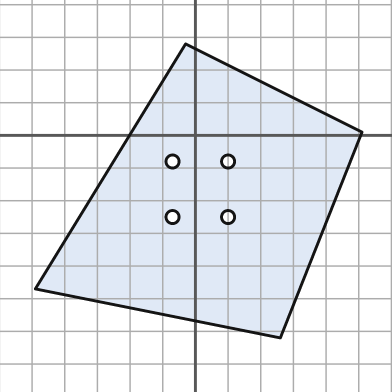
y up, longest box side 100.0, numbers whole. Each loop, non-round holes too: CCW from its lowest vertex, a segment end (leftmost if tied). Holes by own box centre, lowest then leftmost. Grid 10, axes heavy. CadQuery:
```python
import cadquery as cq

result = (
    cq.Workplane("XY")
    .moveTo(26.0, -62.0)
    .lineTo(51.0, 1.0)
    .lineTo(-3.0, 28.0)
    .lineTo(-49.0, -47.0)
    .close()
    .moveTo(-7.0, -25.0)
    .circle(2.0)
    .moveTo(10.0, -25.0)
    .circle(2.0)
    .moveTo(-7.0, -8.0)
    .circle(2.0)
    .moveTo(10.0, -8.0)
    .circle(2.0)
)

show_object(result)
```